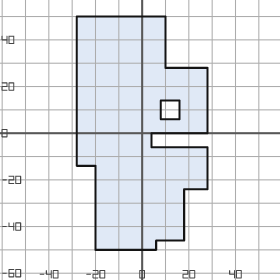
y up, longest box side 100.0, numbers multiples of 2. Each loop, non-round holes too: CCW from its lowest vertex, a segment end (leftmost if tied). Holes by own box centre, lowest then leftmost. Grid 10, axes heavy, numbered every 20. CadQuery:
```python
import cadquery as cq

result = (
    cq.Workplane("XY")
    .moveTo(-20.0, -50.0)
    .lineTo(6.0, -50.0)
    .lineTo(6.0, -46.0)
    .lineTo(18.0, -46.0)
    .lineTo(18.0, -24.0)
    .lineTo(28.0, -24.0)
    .lineTo(28.0, -6.0)
    .lineTo(4.0, -6.0)
    .lineTo(4.0, 0.0)
    .lineTo(28.0, 0.0)
    .lineTo(28.0, 28.0)
    .lineTo(10.0, 28.0)
    .lineTo(10.0, 50.0)
    .lineTo(-28.0, 50.0)
    .lineTo(-28.0, -14.0)
    .lineTo(-20.0, -14.0)
    .close()
    .moveTo(8.0, 6.0)
    .lineTo(16.0, 6.0)
    .lineTo(16.0, 14.0)
    .lineTo(8.0, 14.0)
    .close()
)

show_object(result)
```